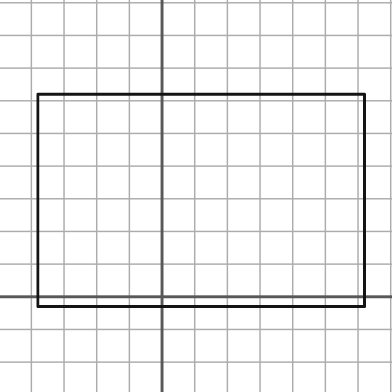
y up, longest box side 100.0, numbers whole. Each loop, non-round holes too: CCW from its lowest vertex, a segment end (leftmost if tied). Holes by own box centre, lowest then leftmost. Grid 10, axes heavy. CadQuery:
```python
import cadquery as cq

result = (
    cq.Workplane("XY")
    .moveTo(-38.0, -3.0)
    .lineTo(62.0, -3.0)
    .lineTo(62.0, 62.0)
    .lineTo(-38.0, 62.0)
    .close()
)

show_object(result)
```